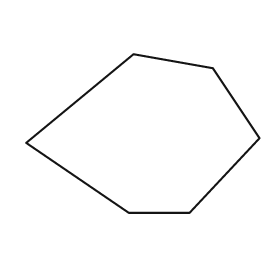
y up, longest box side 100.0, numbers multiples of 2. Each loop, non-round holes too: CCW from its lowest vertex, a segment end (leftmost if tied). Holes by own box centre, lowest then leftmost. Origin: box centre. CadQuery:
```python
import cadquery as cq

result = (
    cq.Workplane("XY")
    .moveTo(-6.0, -34.0)
    .lineTo(20.0, -34.0)
    .lineTo(50.0, -2.0)
    .lineTo(30.0, 28.0)
    .lineTo(-4.0, 34.0)
    .lineTo(-50.0, -4.0)
    .close()
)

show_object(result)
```